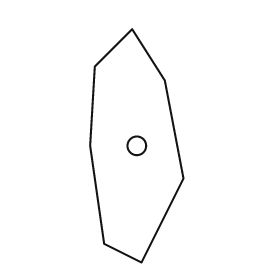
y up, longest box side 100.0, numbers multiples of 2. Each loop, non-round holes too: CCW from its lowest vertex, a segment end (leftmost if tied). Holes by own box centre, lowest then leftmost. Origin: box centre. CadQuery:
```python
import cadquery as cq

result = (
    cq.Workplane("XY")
    .moveTo(2.0, -50.0)
    .lineTo(20.0, -14.0)
    .lineTo(12.0, 28.0)
    .lineTo(-2.0, 50.0)
    .lineTo(-18.0, 34.0)
    .lineTo(-20.0, 0.0)
    .lineTo(-14.0, -42.0)
    .close()
    .moveTo(0.0, 0.0)
    .circle(4.0)
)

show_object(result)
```